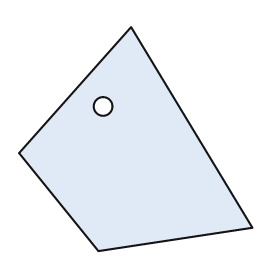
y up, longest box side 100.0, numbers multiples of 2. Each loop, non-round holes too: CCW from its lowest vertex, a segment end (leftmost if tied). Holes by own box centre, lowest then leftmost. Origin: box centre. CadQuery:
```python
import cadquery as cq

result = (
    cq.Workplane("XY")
    .moveTo(-16.0, -48.0)
    .lineTo(50.0, -38.0)
    .lineTo(-2.0, 48.0)
    .lineTo(-50.0, -6.0)
    .close()
    .moveTo(-14.0, 14.0)
    .circle(4.0)
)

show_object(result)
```